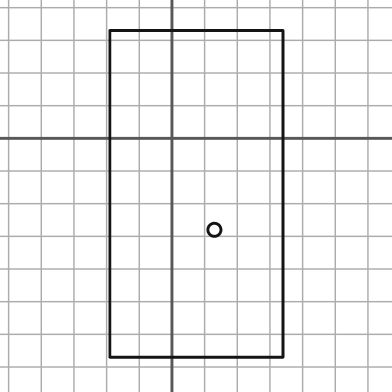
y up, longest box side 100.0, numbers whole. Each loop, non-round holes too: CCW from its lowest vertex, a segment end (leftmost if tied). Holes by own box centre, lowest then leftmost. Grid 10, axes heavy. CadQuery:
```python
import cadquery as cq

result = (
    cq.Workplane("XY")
    .moveTo(-19.0, -67.0)
    .lineTo(34.0, -67.0)
    .lineTo(34.0, 33.0)
    .lineTo(-19.0, 33.0)
    .close()
    .moveTo(13.0, -28.0)
    .circle(2.0)
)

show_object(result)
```